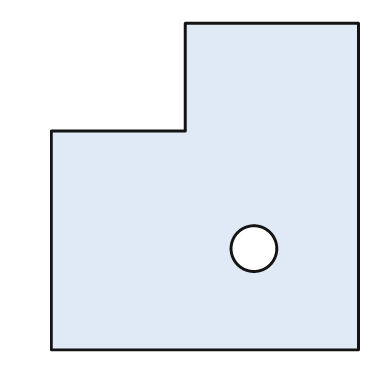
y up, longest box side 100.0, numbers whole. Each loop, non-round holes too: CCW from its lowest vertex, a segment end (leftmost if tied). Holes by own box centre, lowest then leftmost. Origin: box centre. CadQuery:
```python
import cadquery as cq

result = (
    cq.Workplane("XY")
    .moveTo(-47.0, -50.0)
    .lineTo(47.0, -50.0)
    .lineTo(47.0, 50.0)
    .lineTo(-6.0, 50.0)
    .lineTo(-6.0, 17.0)
    .lineTo(-47.0, 17.0)
    .close()
    .moveTo(15.0, -19.0)
    .circle(7.0)
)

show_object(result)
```